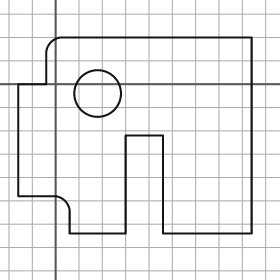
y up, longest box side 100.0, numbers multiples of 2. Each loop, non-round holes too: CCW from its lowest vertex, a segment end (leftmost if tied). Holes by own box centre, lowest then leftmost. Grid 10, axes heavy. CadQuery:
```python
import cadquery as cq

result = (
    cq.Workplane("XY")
    .moveTo(6.0, -64.0)
    .lineTo(30.0, -64.0)
    .lineTo(30.0, -22.0)
    .lineTo(46.0, -22.0)
    .lineTo(46.0, -64.0)
    .lineTo(84.0, -64.0)
    .lineTo(84.0, 20.0)
    .lineTo(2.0, 20.0)
    .threePointArc((-2.0, 18.0), (-4.0, 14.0))
    .lineTo(-4.0, 0.0)
    .lineTo(-16.0, 0.0)
    .lineTo(-16.0, -48.0)
    .lineTo(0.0, -48.0)
    .threePointArc((4.0, -50.0), (6.0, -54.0))
    .close()
    .moveTo(18.0, -4.0)
    .circle(10.0)
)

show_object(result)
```